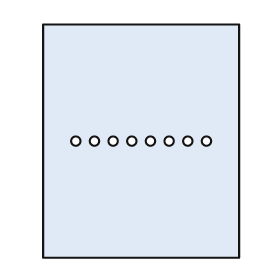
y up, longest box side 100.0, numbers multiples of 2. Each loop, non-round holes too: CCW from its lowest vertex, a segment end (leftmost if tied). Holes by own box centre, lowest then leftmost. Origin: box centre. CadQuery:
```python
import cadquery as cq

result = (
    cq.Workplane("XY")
    .moveTo(-42.0, -50.0)
    .lineTo(42.0, -50.0)
    .lineTo(42.0, 50.0)
    .lineTo(-42.0, 50.0)
    .close()
    .moveTo(-28.0, 0.0)
    .circle(2.0)
    .moveTo(-20.0, 0.0)
    .circle(2.0)
    .moveTo(-12.0, 0.0)
    .circle(2.0)
    .moveTo(-4.0, 0.0)
    .circle(2.0)
    .moveTo(4.0, 0.0)
    .circle(2.0)
    .moveTo(12.0, 0.0)
    .circle(2.0)
    .moveTo(20.0, 0.0)
    .circle(2.0)
    .moveTo(28.0, 0.0)
    .circle(2.0)
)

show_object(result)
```